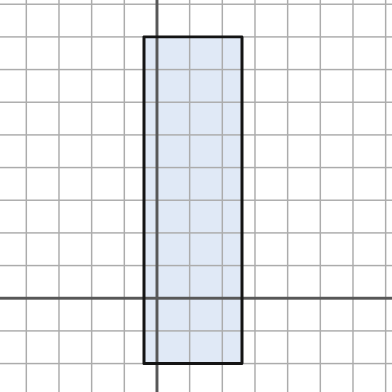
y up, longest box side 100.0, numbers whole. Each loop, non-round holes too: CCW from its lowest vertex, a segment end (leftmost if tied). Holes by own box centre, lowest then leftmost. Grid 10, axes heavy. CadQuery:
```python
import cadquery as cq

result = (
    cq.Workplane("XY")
    .moveTo(-4.0, -20.0)
    .lineTo(26.0, -20.0)
    .lineTo(26.0, 80.0)
    .lineTo(-4.0, 80.0)
    .close()
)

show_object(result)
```